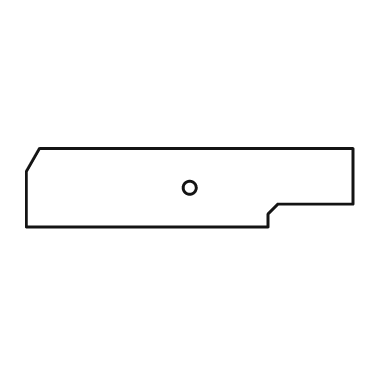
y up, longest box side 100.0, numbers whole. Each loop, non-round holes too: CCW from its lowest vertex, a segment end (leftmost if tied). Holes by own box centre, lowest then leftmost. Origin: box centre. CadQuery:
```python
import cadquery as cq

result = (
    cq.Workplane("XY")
    .moveTo(-50.0, -12.0)
    .lineTo(24.0, -12.0)
    .lineTo(24.0, -8.0)
    .lineTo(27.0, -5.0)
    .lineTo(50.0, -5.0)
    .lineTo(50.0, 12.0)
    .lineTo(-46.0, 12.0)
    .lineTo(-50.0, 5.0)
    .close()
    .moveTo(0.0, 0.0)
    .circle(2.0)
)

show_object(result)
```